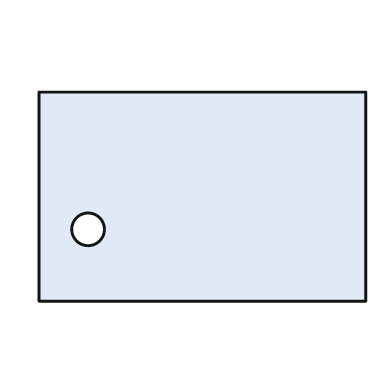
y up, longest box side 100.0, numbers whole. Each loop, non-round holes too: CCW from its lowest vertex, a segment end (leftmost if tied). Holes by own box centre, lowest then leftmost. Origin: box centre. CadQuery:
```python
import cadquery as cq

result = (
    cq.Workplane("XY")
    .moveTo(-50.0, -32.0)
    .lineTo(50.0, -32.0)
    .lineTo(50.0, 32.0)
    .lineTo(-50.0, 32.0)
    .close()
    .moveTo(-35.0, -10.0)
    .circle(5.0)
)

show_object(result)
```